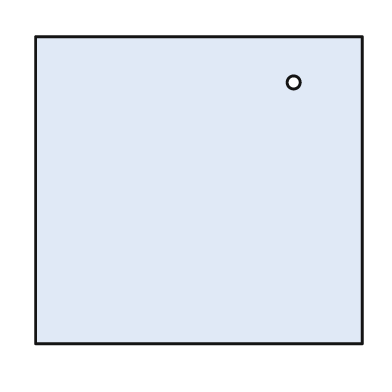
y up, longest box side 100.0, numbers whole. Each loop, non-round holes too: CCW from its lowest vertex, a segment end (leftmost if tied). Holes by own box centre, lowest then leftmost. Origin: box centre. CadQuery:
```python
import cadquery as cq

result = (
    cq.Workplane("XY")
    .moveTo(-50.0, -47.0)
    .lineTo(50.0, -47.0)
    .lineTo(50.0, 47.0)
    .lineTo(-50.0, 47.0)
    .close()
    .moveTo(29.0, 33.0)
    .circle(2.0)
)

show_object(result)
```